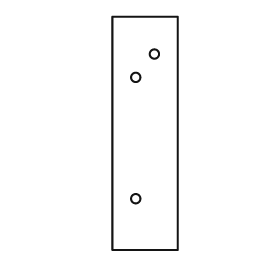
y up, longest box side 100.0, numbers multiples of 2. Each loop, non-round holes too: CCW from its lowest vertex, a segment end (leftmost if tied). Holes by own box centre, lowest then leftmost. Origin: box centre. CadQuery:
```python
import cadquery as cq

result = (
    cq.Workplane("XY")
    .moveTo(-14.0, -50.0)
    .lineTo(14.0, -50.0)
    .lineTo(14.0, 50.0)
    .lineTo(-14.0, 50.0)
    .close()
    .moveTo(-4.0, -28.0)
    .circle(2.0)
    .moveTo(-4.0, 24.0)
    .circle(2.0)
    .moveTo(4.0, 34.0)
    .circle(2.0)
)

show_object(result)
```